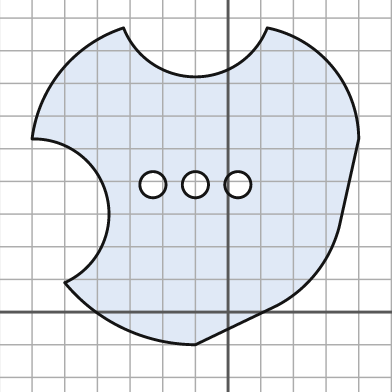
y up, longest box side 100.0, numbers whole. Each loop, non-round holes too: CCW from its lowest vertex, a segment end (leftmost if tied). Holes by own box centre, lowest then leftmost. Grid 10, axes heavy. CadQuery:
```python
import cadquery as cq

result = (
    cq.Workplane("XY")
    .moveTo(-10.0, -10.0)
    .lineTo(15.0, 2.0)
    .threePointArc((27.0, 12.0), (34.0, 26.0))
    .lineTo(40.0, 53.0)
    .threePointArc((32.0, 75.0), (12.0, 87.0))
    .threePointArc((-10.0, 72.0), (-32.0, 87.0))
    .threePointArc((-51.0, 74.0), (-60.0, 53.0))
    .threePointArc((-37.0, 35.0), (-50.0, 9.0))
    .threePointArc((-32.0, -5.0), (-10.0, -10.0))
    .close()
    .moveTo(-23.0, 39.0)
    .circle(4.0)
    .moveTo(-10.0, 39.0)
    .circle(4.0)
    .moveTo(3.0, 39.0)
    .circle(4.0)
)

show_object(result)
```